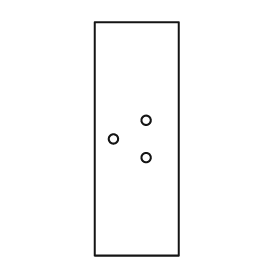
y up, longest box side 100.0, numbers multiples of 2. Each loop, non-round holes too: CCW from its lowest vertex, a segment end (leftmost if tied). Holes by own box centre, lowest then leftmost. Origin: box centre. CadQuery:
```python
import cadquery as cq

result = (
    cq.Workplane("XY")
    .moveTo(-18.0, -50.0)
    .lineTo(18.0, -50.0)
    .lineTo(18.0, 50.0)
    .lineTo(-18.0, 50.0)
    .close()
    .moveTo(4.0, -8.0)
    .circle(2.0)
    .moveTo(-10.0, 0.0)
    .circle(2.0)
    .moveTo(4.0, 8.0)
    .circle(2.0)
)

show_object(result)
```